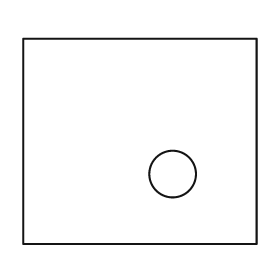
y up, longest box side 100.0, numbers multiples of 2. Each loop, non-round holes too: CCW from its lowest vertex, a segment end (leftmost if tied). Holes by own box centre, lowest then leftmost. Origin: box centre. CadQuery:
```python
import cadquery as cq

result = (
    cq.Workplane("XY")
    .moveTo(-50.0, -44.0)
    .lineTo(50.0, -44.0)
    .lineTo(50.0, 44.0)
    .lineTo(-50.0, 44.0)
    .close()
    .moveTo(14.0, -14.0)
    .circle(10.0)
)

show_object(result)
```